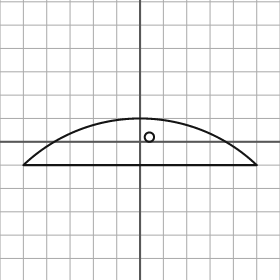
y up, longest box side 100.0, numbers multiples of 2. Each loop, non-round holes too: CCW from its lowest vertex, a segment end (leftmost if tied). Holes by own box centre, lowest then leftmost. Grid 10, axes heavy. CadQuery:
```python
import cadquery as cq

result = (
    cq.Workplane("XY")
    .moveTo(-50.0, -10.0)
    .lineTo(50.0, -10.0)
    .threePointArc((0.0, 10.0), (-50.0, -10.0))
    .close()
    .moveTo(4.0, 2.0)
    .circle(2.0)
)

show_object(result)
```